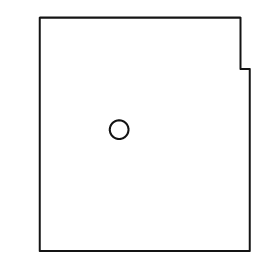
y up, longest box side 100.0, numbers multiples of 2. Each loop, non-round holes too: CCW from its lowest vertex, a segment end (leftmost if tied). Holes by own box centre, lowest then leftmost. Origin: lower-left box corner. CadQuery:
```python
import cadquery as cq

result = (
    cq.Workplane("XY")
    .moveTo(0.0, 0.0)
    .lineTo(90.0, 0.0)
    .lineTo(90.0, 78.0)
    .lineTo(86.0, 78.0)
    .lineTo(86.0, 100.0)
    .lineTo(0.0, 100.0)
    .close()
    .moveTo(34.0, 52.0)
    .circle(4.0)
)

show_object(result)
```